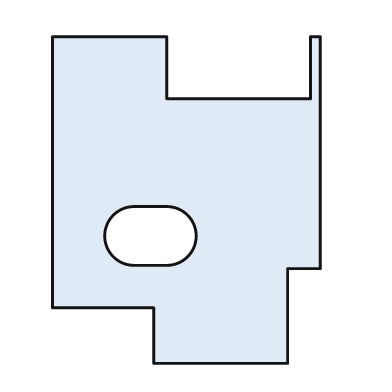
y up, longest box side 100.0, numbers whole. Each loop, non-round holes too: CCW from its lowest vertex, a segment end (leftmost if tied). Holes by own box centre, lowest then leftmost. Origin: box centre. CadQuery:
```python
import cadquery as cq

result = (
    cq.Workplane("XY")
    .moveTo(-10.0, -50.0)
    .lineTo(31.0, -50.0)
    .lineTo(31.0, -21.0)
    .lineTo(41.0, -21.0)
    .lineTo(41.0, 50.0)
    .lineTo(38.0, 50.0)
    .lineTo(38.0, 31.0)
    .lineTo(-6.0, 31.0)
    .lineTo(-6.0, 50.0)
    .lineTo(-41.0, 50.0)
    .lineTo(-41.0, -33.0)
    .lineTo(-10.0, -33.0)
    .close()
    .moveTo(-16.0, -20.0)
    .lineTo(-6.0, -20.0)
    .threePointArc((3.0, -11.0), (-6.0, -2.0))
    .lineTo(-16.0, -2.0)
    .threePointArc((-25.0, -11.0), (-16.0, -20.0))
    .close()
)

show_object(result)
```